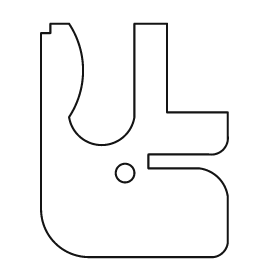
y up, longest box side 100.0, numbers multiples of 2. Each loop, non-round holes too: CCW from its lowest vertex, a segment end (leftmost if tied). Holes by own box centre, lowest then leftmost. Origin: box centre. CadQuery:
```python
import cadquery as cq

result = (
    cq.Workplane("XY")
    .moveTo(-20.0, -50.0)
    .lineTo(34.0, -50.0)
    .threePointArc((38.0, -48.0), (40.0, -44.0))
    .lineTo(40.0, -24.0)
    .threePointArc((36.0, -16.0), (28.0, -12.0))
    .lineTo(6.0, -12.0)
    .lineTo(6.0, -6.0)
    .lineTo(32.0, -6.0)
    .threePointArc((38.0, -4.0), (40.0, 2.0))
    .lineTo(40.0, 12.0)
    .lineTo(14.0, 12.0)
    .lineTo(14.0, 50.0)
    .lineTo(0.0, 50.0)
    .lineTo(0.0, 10.0)
    .threePointArc((-14.0, -2.0), (-28.0, 10.0))
    .threePointArc((-22.0, 30.0), (-28.0, 50.0))
    .lineTo(-36.0, 50.0)
    .lineTo(-36.0, 46.0)
    .lineTo(-40.0, 46.0)
    .lineTo(-40.0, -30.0)
    .threePointArc((-34.0, -44.0), (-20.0, -50.0))
    .close()
    .moveTo(-4.0, -14.0)
    .circle(4.0)
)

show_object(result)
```